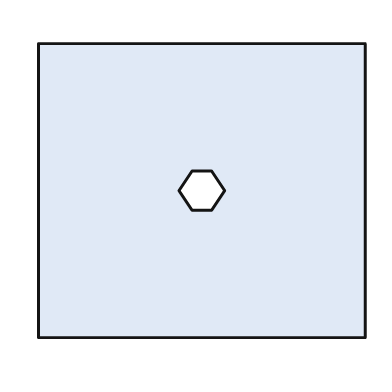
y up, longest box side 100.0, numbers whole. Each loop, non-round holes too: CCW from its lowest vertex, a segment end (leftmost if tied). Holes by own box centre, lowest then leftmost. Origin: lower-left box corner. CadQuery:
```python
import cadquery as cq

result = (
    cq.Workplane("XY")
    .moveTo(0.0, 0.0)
    .lineTo(100.0, 0.0)
    .lineTo(100.0, 90.0)
    .lineTo(0.0, 90.0)
    .close()
    .moveTo(47.0, 39.0)
    .lineTo(53.0, 39.0)
    .lineTo(57.0, 45.0)
    .lineTo(53.0, 51.0)
    .lineTo(47.0, 51.0)
    .lineTo(43.0, 45.0)
    .close()
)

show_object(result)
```